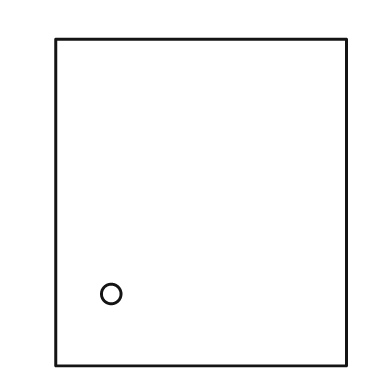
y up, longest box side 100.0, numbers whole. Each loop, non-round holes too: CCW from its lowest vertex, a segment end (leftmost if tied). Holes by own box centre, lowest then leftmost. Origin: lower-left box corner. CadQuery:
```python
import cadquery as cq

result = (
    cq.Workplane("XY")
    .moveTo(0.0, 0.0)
    .lineTo(89.0, 0.0)
    .lineTo(89.0, 100.0)
    .lineTo(0.0, 100.0)
    .close()
    .moveTo(17.0, 22.0)
    .circle(3.0)
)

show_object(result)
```